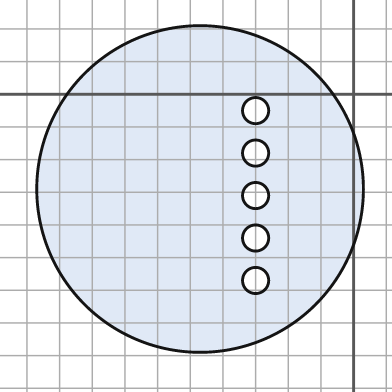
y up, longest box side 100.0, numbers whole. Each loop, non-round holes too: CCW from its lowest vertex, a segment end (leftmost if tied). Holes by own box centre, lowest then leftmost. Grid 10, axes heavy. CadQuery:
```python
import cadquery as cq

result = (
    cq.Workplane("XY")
    .moveTo(-47.0, -29.0)
    .circle(50.0)
    .moveTo(-30.0, -57.0)
    .circle(4.0)
    .moveTo(-30.0, -44.0)
    .circle(4.0)
    .moveTo(-30.0, -31.0)
    .circle(4.0)
    .moveTo(-30.0, -18.0)
    .circle(4.0)
    .moveTo(-30.0, -5.0)
    .circle(4.0)
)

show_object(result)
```